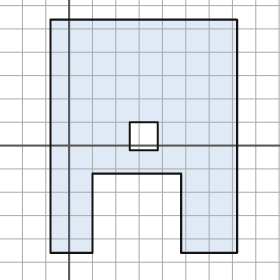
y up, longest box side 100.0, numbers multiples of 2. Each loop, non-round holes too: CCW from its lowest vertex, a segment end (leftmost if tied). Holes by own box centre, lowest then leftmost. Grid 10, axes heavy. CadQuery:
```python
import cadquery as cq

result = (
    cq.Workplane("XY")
    .moveTo(-8.0, -46.0)
    .lineTo(10.0, -46.0)
    .lineTo(10.0, -12.0)
    .lineTo(48.0, -12.0)
    .lineTo(48.0, -46.0)
    .lineTo(72.0, -46.0)
    .lineTo(72.0, 54.0)
    .lineTo(-8.0, 54.0)
    .close()
    .moveTo(26.0, -2.0)
    .lineTo(38.0, -2.0)
    .lineTo(38.0, 10.0)
    .lineTo(26.0, 10.0)
    .close()
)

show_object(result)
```